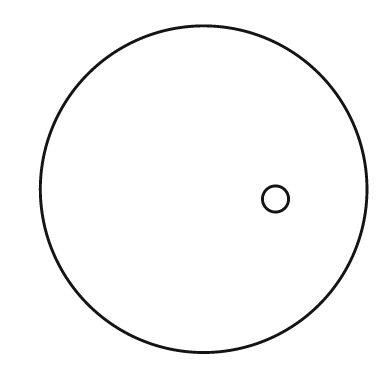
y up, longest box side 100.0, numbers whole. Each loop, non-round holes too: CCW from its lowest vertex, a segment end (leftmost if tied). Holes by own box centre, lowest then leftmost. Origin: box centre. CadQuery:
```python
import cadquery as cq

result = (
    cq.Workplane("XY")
    .moveTo(0.0, 0.0)
    .circle(50.0)
    .moveTo(22.0, -3.0)
    .circle(4.0)
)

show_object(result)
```